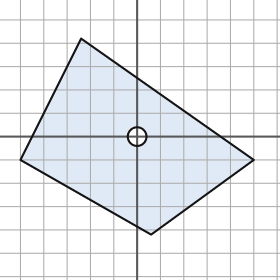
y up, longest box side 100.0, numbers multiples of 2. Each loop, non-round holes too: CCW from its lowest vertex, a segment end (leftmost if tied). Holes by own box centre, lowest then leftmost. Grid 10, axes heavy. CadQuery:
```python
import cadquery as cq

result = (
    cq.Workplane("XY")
    .moveTo(6.0, -42.0)
    .lineTo(50.0, -10.0)
    .lineTo(-24.0, 42.0)
    .lineTo(-50.0, -10.0)
    .close()
    .moveTo(0.0, 0.0)
    .circle(4.0)
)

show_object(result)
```